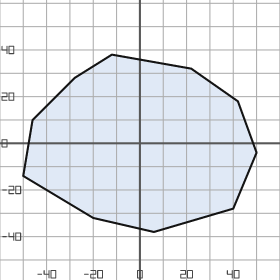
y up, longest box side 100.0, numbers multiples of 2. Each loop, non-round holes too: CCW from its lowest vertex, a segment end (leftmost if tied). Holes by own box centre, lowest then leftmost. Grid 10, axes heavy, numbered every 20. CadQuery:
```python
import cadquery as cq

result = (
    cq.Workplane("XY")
    .moveTo(6.0, -38.0)
    .lineTo(40.0, -28.0)
    .lineTo(50.0, -4.0)
    .lineTo(42.0, 18.0)
    .lineTo(22.0, 32.0)
    .lineTo(-12.0, 38.0)
    .lineTo(-28.0, 28.0)
    .lineTo(-46.0, 10.0)
    .lineTo(-50.0, -14.0)
    .lineTo(-20.0, -32.0)
    .close()
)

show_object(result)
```